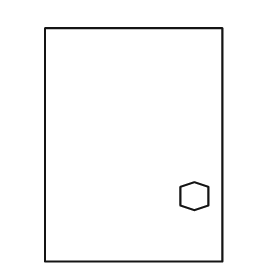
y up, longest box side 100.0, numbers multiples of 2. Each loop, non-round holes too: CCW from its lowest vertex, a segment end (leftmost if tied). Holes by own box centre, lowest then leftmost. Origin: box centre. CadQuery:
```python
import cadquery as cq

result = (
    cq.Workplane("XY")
    .moveTo(-38.0, -50.0)
    .lineTo(38.0, -50.0)
    .lineTo(38.0, 50.0)
    .lineTo(-38.0, 50.0)
    .close()
    .moveTo(26.0, -28.0)
    .lineTo(32.0, -26.0)
    .lineTo(32.0, -18.0)
    .lineTo(26.0, -16.0)
    .lineTo(20.0, -18.0)
    .lineTo(20.0, -26.0)
    .close()
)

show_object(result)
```